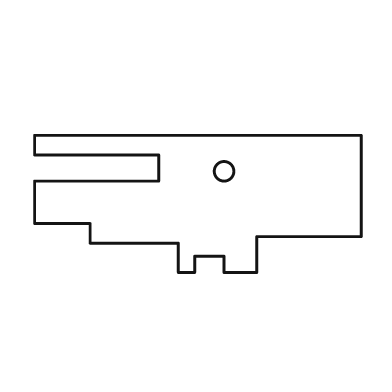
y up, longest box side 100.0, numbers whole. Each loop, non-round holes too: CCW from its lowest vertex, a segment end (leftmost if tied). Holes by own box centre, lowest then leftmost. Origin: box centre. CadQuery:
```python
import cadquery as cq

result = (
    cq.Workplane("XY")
    .moveTo(-6.0, -21.0)
    .lineTo(-1.0, -21.0)
    .lineTo(-1.0, -16.0)
    .lineTo(8.0, -16.0)
    .lineTo(8.0, -21.0)
    .lineTo(18.0, -21.0)
    .lineTo(18.0, -10.0)
    .lineTo(50.0, -10.0)
    .lineTo(50.0, 21.0)
    .lineTo(-50.0, 21.0)
    .lineTo(-50.0, 15.0)
    .lineTo(-12.0, 15.0)
    .lineTo(-12.0, 7.0)
    .lineTo(-50.0, 7.0)
    .lineTo(-50.0, -6.0)
    .lineTo(-33.0, -6.0)
    .lineTo(-33.0, -12.0)
    .lineTo(-6.0, -12.0)
    .close()
    .moveTo(8.0, 10.0)
    .circle(3.0)
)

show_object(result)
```